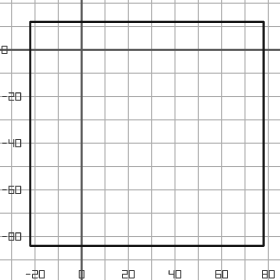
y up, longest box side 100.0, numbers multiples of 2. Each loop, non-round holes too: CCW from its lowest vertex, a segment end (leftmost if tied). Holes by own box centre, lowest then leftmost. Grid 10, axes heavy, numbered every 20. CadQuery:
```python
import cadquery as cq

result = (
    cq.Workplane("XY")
    .moveTo(-22.0, -84.0)
    .lineTo(78.0, -84.0)
    .lineTo(78.0, 12.0)
    .lineTo(-22.0, 12.0)
    .close()
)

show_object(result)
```